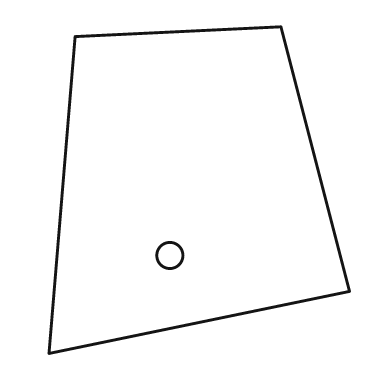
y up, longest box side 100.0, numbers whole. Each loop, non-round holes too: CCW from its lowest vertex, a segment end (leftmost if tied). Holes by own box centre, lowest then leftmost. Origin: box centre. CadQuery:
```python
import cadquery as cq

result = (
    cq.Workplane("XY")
    .moveTo(-46.0, -50.0)
    .lineTo(46.0, -31.0)
    .lineTo(25.0, 50.0)
    .lineTo(-38.0, 47.0)
    .close()
    .moveTo(-9.0, -20.0)
    .circle(4.0)
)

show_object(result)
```